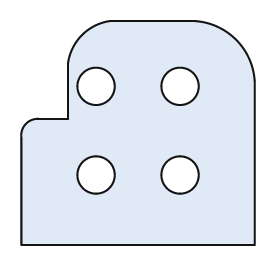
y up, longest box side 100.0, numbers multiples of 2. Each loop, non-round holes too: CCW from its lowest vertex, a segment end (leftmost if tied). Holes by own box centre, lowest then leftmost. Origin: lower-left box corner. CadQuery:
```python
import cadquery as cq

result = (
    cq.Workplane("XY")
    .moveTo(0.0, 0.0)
    .lineTo(100.0, 0.0)
    .lineTo(100.0, 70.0)
    .threePointArc((92.0, 88.0), (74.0, 96.0))
    .lineTo(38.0, 96.0)
    .threePointArc((26.0, 90.0), (20.0, 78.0))
    .lineTo(20.0, 54.0)
    .lineTo(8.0, 54.0)
    .threePointArc((2.0, 52.0), (0.0, 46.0))
    .close()
    .moveTo(32.0, 30.0)
    .circle(8.0)
    .moveTo(68.0, 30.0)
    .circle(8.0)
    .moveTo(32.0, 68.0)
    .circle(8.0)
    .moveTo(68.0, 68.0)
    .circle(8.0)
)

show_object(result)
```